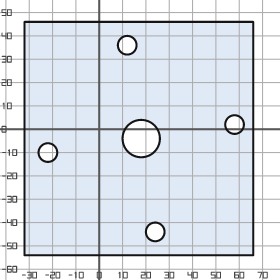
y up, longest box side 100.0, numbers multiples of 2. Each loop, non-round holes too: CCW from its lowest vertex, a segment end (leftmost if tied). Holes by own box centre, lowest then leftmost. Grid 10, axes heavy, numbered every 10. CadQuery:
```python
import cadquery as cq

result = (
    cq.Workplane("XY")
    .moveTo(-32.0, -54.0)
    .lineTo(66.0, -54.0)
    .lineTo(66.0, 46.0)
    .lineTo(-32.0, 46.0)
    .close()
    .moveTo(24.0, -44.0)
    .circle(4.0)
    .moveTo(-22.0, -10.0)
    .circle(4.0)
    .moveTo(18.0, -4.0)
    .circle(8.0)
    .moveTo(58.0, 2.0)
    .circle(4.0)
    .moveTo(12.0, 36.0)
    .circle(4.0)
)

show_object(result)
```